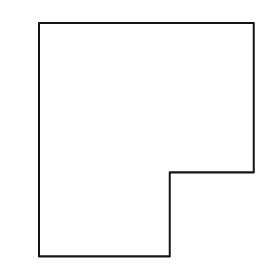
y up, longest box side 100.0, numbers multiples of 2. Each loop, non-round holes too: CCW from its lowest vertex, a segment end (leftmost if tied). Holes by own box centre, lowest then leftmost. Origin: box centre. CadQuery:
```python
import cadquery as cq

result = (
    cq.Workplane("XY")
    .moveTo(-46.0, -50.0)
    .lineTo(10.0, -50.0)
    .lineTo(10.0, -14.0)
    .lineTo(46.0, -14.0)
    .lineTo(46.0, 50.0)
    .lineTo(-46.0, 50.0)
    .close()
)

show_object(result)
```